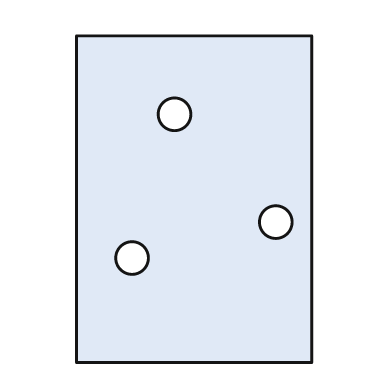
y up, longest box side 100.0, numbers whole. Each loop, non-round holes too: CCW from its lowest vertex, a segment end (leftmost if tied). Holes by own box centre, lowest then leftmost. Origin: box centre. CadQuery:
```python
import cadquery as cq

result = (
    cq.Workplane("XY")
    .moveTo(-36.0, -50.0)
    .lineTo(36.0, -50.0)
    .lineTo(36.0, 50.0)
    .lineTo(-36.0, 50.0)
    .close()
    .moveTo(-19.0, -18.0)
    .circle(5.0)
    .moveTo(25.0, -7.0)
    .circle(5.0)
    .moveTo(-6.0, 26.0)
    .circle(5.0)
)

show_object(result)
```